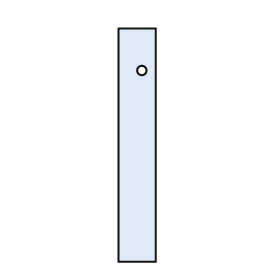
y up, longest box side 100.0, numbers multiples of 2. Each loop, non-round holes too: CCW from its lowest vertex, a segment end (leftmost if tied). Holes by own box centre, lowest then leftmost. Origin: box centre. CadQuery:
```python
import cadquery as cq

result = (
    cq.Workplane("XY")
    .moveTo(-8.0, -50.0)
    .lineTo(8.0, -50.0)
    .lineTo(8.0, 50.0)
    .lineTo(-8.0, 50.0)
    .close()
    .moveTo(2.0, 32.0)
    .circle(2.0)
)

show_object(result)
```